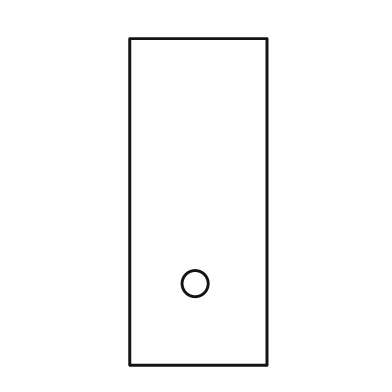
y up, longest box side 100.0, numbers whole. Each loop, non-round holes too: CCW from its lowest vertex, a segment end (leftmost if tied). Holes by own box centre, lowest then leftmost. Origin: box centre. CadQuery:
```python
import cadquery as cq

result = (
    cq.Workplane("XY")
    .moveTo(-21.0, -50.0)
    .lineTo(21.0, -50.0)
    .lineTo(21.0, 50.0)
    .lineTo(-21.0, 50.0)
    .close()
    .moveTo(-1.0, -25.0)
    .circle(4.0)
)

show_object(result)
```